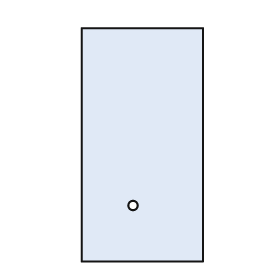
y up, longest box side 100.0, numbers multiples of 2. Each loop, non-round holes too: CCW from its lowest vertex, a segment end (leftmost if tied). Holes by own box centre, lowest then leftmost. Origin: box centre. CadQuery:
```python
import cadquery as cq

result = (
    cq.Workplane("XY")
    .moveTo(-26.0, -50.0)
    .lineTo(26.0, -50.0)
    .lineTo(26.0, 50.0)
    .lineTo(-26.0, 50.0)
    .close()
    .moveTo(-4.0, -26.0)
    .circle(2.0)
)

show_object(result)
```